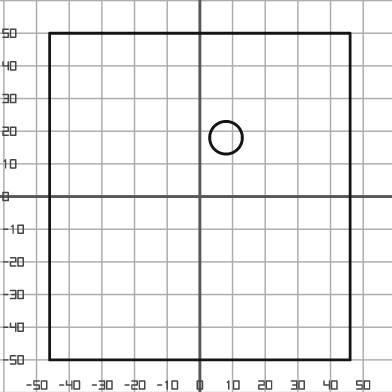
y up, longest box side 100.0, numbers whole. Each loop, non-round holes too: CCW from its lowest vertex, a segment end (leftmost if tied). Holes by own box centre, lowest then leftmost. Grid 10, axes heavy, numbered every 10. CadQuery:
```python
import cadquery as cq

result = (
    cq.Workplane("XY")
    .moveTo(-46.0, -50.0)
    .lineTo(46.0, -50.0)
    .lineTo(46.0, 50.0)
    .lineTo(-46.0, 50.0)
    .close()
    .moveTo(8.0, 18.0)
    .circle(5.0)
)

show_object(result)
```